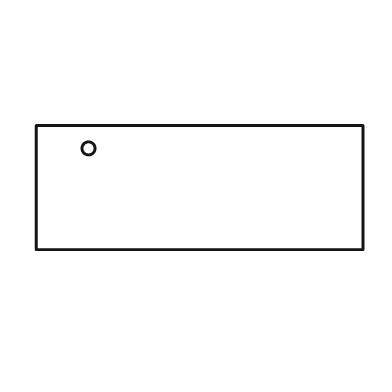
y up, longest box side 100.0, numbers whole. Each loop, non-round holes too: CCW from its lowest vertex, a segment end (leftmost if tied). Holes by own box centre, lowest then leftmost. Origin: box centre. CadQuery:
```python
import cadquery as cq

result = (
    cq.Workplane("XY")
    .moveTo(-50.0, -19.0)
    .lineTo(50.0, -19.0)
    .lineTo(50.0, 19.0)
    .lineTo(-50.0, 19.0)
    .close()
    .moveTo(-34.0, 12.0)
    .circle(2.0)
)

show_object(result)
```